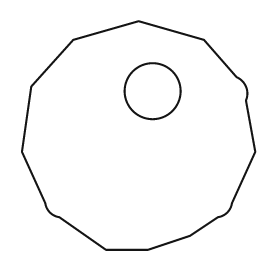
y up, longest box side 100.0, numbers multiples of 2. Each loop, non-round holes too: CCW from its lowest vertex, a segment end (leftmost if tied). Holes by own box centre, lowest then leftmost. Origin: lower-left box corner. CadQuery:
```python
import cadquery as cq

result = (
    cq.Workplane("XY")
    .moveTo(36.0, 0.0)
    .lineTo(54.0, 0.0)
    .lineTo(72.0, 6.0)
    .lineTo(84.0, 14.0)
    .threePointArc((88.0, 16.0), (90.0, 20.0))
    .lineTo(100.0, 42.0)
    .lineTo(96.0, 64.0)
    .threePointArc((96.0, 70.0), (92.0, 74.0))
    .lineTo(78.0, 90.0)
    .lineTo(50.0, 98.0)
    .lineTo(22.0, 90.0)
    .lineTo(4.0, 70.0)
    .lineTo(0.0, 42.0)
    .lineTo(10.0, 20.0)
    .threePointArc((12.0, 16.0), (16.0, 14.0))
    .close()
    .moveTo(56.0, 68.0)
    .circle(12.0)
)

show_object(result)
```